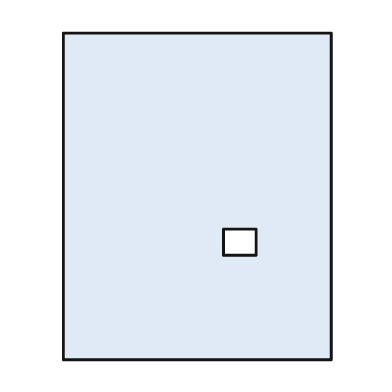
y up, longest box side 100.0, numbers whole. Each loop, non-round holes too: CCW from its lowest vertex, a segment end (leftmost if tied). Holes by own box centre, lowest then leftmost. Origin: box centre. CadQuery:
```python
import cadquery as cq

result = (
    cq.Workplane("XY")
    .moveTo(-41.0, -50.0)
    .lineTo(41.0, -50.0)
    .lineTo(41.0, 50.0)
    .lineTo(-41.0, 50.0)
    .close()
    .moveTo(8.0, -18.0)
    .lineTo(18.0, -18.0)
    .lineTo(18.0, -10.0)
    .lineTo(8.0, -10.0)
    .close()
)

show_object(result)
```